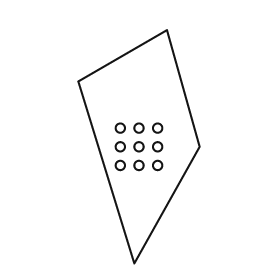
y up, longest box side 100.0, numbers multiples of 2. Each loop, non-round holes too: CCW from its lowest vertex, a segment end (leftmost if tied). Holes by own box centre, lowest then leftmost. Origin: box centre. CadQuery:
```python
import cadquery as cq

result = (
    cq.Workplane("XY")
    .moveTo(-2.0, -50.0)
    .lineTo(26.0, 0.0)
    .lineTo(12.0, 50.0)
    .lineTo(-26.0, 28.0)
    .close()
    .moveTo(-8.0, -8.0)
    .circle(2.0)
    .moveTo(0.0, -8.0)
    .circle(2.0)
    .moveTo(8.0, -8.0)
    .circle(2.0)
    .moveTo(-8.0, 0.0)
    .circle(2.0)
    .moveTo(0.0, 0.0)
    .circle(2.0)
    .moveTo(8.0, 0.0)
    .circle(2.0)
    .moveTo(-8.0, 8.0)
    .circle(2.0)
    .moveTo(0.0, 8.0)
    .circle(2.0)
    .moveTo(8.0, 8.0)
    .circle(2.0)
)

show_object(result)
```